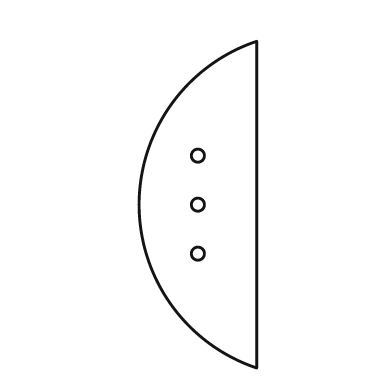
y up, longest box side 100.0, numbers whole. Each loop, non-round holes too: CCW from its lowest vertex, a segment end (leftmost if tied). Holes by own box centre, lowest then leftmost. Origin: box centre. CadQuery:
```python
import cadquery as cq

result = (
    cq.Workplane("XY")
    .moveTo(18.0, -50.0)
    .lineTo(18.0, 50.0)
    .threePointArc((-18.0, 0.0), (18.0, -50.0))
    .close()
    .moveTo(0.0, -15.0)
    .circle(2.0)
    .moveTo(0.0, 0.0)
    .circle(2.0)
    .moveTo(0.0, 15.0)
    .circle(2.0)
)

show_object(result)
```